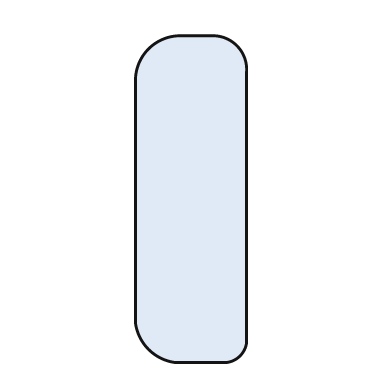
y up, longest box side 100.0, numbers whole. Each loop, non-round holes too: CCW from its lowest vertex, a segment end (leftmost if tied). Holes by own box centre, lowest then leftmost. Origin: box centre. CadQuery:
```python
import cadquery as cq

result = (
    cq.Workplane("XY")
    .moveTo(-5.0, -50.0)
    .lineTo(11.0, -50.0)
    .threePointArc((15.0, -48.0), (17.0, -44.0))
    .lineTo(17.0, 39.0)
    .threePointArc((14.0, 47.0), (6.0, 50.0))
    .lineTo(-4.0, 50.0)
    .threePointArc((-13.0, 46.0), (-17.0, 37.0))
    .lineTo(-17.0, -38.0)
    .threePointArc((-13.0, -46.0), (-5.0, -50.0))
    .close()
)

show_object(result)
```